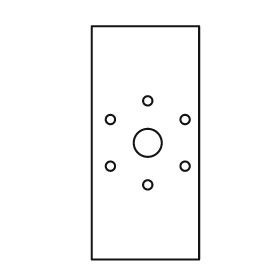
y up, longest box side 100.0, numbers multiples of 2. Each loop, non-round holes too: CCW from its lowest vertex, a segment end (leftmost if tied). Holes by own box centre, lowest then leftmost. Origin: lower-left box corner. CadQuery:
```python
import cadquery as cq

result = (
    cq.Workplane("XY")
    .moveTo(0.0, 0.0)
    .lineTo(46.0, 0.0)
    .lineTo(46.0, 100.0)
    .lineTo(0.0, 100.0)
    .close()
    .moveTo(24.0, 32.0)
    .circle(2.0)
    .moveTo(8.0, 40.0)
    .circle(2.0)
    .moveTo(40.0, 40.0)
    .circle(2.0)
    .moveTo(24.0, 50.0)
    .circle(6.0)
    .moveTo(8.0, 60.0)
    .circle(2.0)
    .moveTo(40.0, 60.0)
    .circle(2.0)
    .moveTo(24.0, 68.0)
    .circle(2.0)
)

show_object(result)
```